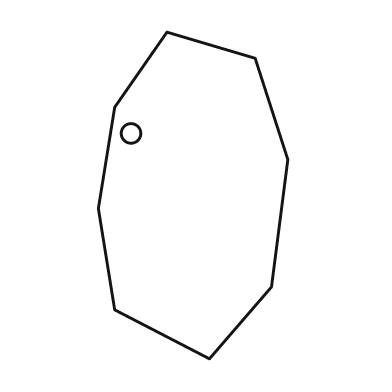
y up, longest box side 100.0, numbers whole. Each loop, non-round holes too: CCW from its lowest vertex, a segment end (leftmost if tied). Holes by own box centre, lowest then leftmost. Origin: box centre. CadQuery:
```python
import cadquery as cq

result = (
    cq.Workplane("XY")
    .moveTo(5.0, -50.0)
    .lineTo(24.0, -28.0)
    .lineTo(29.0, 11.0)
    .lineTo(19.0, 42.0)
    .lineTo(-8.0, 50.0)
    .lineTo(-24.0, 27.0)
    .lineTo(-29.0, -4.0)
    .lineTo(-24.0, -35.0)
    .close()
    .moveTo(-19.0, 19.0)
    .circle(3.0)
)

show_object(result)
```